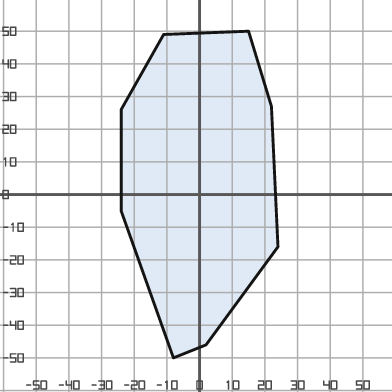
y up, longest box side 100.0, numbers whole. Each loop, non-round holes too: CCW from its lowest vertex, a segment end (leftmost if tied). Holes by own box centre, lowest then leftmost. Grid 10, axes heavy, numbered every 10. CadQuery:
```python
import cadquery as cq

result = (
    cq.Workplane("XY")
    .moveTo(-8.0, -50.0)
    .lineTo(2.0, -46.0)
    .lineTo(24.0, -16.0)
    .lineTo(22.0, 27.0)
    .lineTo(15.0, 50.0)
    .lineTo(-11.0, 49.0)
    .lineTo(-24.0, 26.0)
    .lineTo(-24.0, -5.0)
    .close()
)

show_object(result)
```